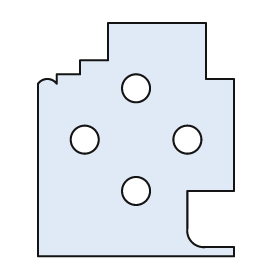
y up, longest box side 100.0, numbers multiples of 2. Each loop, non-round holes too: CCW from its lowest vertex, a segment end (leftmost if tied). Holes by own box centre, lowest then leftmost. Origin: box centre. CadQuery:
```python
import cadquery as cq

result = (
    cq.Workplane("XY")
    .moveTo(-42.0, -50.0)
    .lineTo(42.0, -50.0)
    .lineTo(42.0, -46.0)
    .lineTo(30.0, -46.0)
    .threePointArc((24.0, -44.0), (22.0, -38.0))
    .lineTo(22.0, -22.0)
    .lineTo(42.0, -22.0)
    .lineTo(42.0, 26.0)
    .lineTo(30.0, 26.0)
    .lineTo(30.0, 50.0)
    .lineTo(-12.0, 50.0)
    .lineTo(-12.0, 34.0)
    .lineTo(-24.0, 34.0)
    .lineTo(-24.0, 28.0)
    .lineTo(-34.0, 28.0)
    .lineTo(-34.0, 24.0)
    .threePointArc((-38.0, 26.0), (-42.0, 24.0))
    .close()
    .moveTo(0.0, -22.0)
    .circle(6.0)
    .moveTo(-22.0, 0.0)
    .circle(6.0)
    .moveTo(22.0, 0.0)
    .circle(6.0)
    .moveTo(0.0, 22.0)
    .circle(6.0)
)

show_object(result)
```